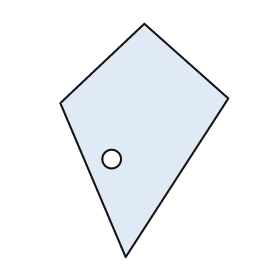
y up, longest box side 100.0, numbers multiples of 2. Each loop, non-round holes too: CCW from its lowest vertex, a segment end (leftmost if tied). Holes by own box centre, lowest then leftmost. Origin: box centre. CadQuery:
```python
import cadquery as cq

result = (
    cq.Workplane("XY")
    .moveTo(-8.0, -50.0)
    .lineTo(36.0, 18.0)
    .lineTo(0.0, 50.0)
    .lineTo(-36.0, 16.0)
    .close()
    .moveTo(-14.0, -8.0)
    .circle(4.0)
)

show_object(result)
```